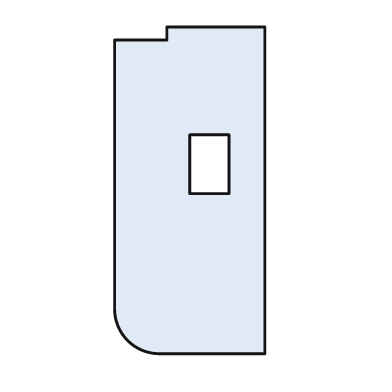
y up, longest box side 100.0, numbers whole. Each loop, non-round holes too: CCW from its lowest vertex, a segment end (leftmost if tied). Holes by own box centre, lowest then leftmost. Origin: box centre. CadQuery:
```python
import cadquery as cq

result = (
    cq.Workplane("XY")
    .moveTo(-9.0, -50.0)
    .lineTo(23.0, -50.0)
    .lineTo(23.0, 50.0)
    .lineTo(-7.0, 50.0)
    .lineTo(-7.0, 46.0)
    .lineTo(-23.0, 46.0)
    .lineTo(-23.0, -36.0)
    .threePointArc((-19.0, -46.0), (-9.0, -50.0))
    .close()
    .moveTo(0.0, -1.0)
    .lineTo(12.0, -1.0)
    .lineTo(12.0, 17.0)
    .lineTo(0.0, 17.0)
    .close()
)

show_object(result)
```